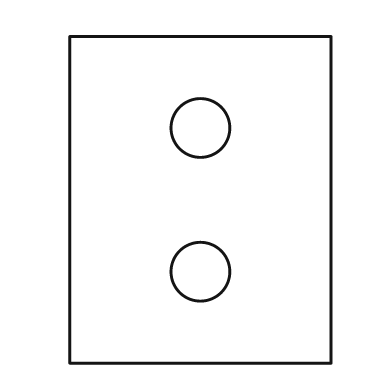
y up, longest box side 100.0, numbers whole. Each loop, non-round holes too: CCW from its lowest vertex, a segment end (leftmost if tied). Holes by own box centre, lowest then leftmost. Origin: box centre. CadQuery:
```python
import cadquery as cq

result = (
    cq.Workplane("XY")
    .moveTo(-40.0, -50.0)
    .lineTo(40.0, -50.0)
    .lineTo(40.0, 50.0)
    .lineTo(-40.0, 50.0)
    .close()
    .moveTo(0.0, -22.0)
    .circle(9.0)
    .moveTo(0.0, 22.0)
    .circle(9.0)
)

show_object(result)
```